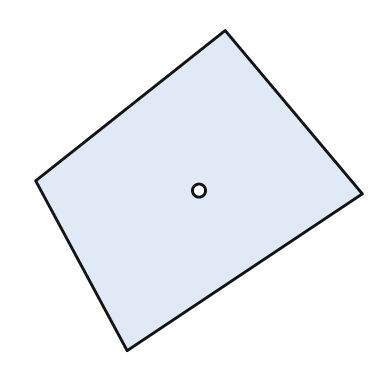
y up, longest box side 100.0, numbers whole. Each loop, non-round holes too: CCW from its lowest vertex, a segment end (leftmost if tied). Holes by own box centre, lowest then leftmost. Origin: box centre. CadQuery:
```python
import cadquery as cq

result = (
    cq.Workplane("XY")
    .moveTo(-22.0, -49.0)
    .lineTo(50.0, -1.0)
    .lineTo(8.0, 49.0)
    .lineTo(-50.0, 3.0)
    .close()
    .moveTo(0.0, 0.0)
    .circle(2.0)
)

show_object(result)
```